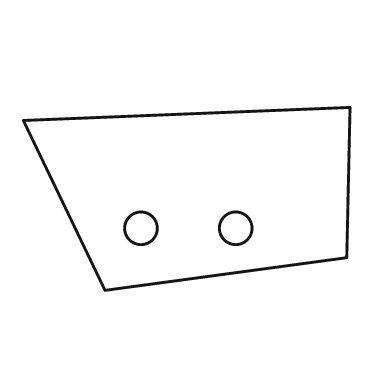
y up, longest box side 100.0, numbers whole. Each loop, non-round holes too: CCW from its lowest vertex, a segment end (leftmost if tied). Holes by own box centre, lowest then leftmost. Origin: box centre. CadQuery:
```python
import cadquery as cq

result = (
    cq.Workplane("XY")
    .moveTo(-25.0, -28.0)
    .lineTo(49.0, -18.0)
    .lineTo(50.0, 28.0)
    .lineTo(-50.0, 24.0)
    .close()
    .moveTo(-14.0, -9.0)
    .circle(5.0)
    .moveTo(15.0, -9.0)
    .circle(5.0)
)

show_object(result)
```